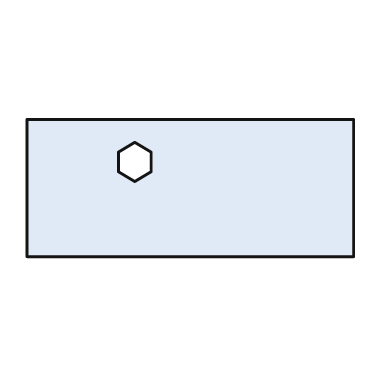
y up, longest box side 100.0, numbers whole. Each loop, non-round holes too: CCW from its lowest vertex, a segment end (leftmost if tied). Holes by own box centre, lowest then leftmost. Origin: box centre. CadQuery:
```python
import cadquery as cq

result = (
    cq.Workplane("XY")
    .moveTo(-50.0, -21.0)
    .lineTo(50.0, -21.0)
    .lineTo(50.0, 21.0)
    .lineTo(-50.0, 21.0)
    .close()
    .moveTo(-17.0, 2.0)
    .lineTo(-12.0, 5.0)
    .lineTo(-12.0, 11.0)
    .lineTo(-17.0, 14.0)
    .lineTo(-22.0, 11.0)
    .lineTo(-22.0, 5.0)
    .close()
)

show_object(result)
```